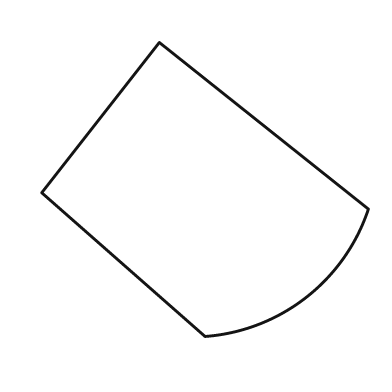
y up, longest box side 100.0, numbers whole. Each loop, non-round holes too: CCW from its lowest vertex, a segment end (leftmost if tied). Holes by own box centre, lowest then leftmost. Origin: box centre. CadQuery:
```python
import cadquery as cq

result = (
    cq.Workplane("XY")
    .moveTo(0.0, -45.0)
    .threePointArc((31.0, -33.0), (50.0, -6.0))
    .lineTo(-14.0, 45.0)
    .lineTo(-50.0, -1.0)
    .close()
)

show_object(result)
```